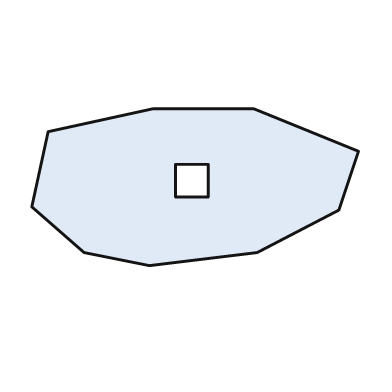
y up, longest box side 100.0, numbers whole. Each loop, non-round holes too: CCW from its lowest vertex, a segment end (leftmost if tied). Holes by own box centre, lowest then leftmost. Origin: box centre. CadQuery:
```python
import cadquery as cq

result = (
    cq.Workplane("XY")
    .moveTo(-14.0, -24.0)
    .lineTo(19.0, -20.0)
    .lineTo(44.0, -7.0)
    .lineTo(50.0, 11.0)
    .lineTo(18.0, 24.0)
    .lineTo(-13.0, 24.0)
    .lineTo(-45.0, 17.0)
    .lineTo(-50.0, -6.0)
    .lineTo(-34.0, -20.0)
    .close()
    .moveTo(-6.0, -3.0)
    .lineTo(4.0, -3.0)
    .lineTo(4.0, 7.0)
    .lineTo(-6.0, 7.0)
    .close()
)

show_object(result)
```